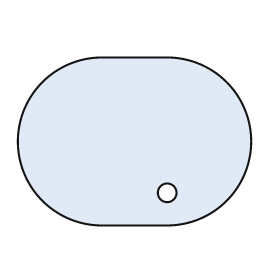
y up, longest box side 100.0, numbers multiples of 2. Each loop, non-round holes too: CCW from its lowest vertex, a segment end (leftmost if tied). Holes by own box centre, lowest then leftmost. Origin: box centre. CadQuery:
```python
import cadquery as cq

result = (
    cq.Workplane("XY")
    .moveTo(-14.0, -36.0)
    .lineTo(14.0, -36.0)
    .threePointArc((50.0, 0.0), (14.0, 36.0))
    .lineTo(-14.0, 36.0)
    .threePointArc((-50.0, 0.0), (-14.0, -36.0))
    .close()
    .moveTo(14.0, -22.0)
    .circle(4.0)
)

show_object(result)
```